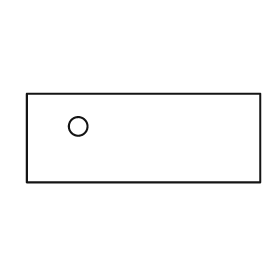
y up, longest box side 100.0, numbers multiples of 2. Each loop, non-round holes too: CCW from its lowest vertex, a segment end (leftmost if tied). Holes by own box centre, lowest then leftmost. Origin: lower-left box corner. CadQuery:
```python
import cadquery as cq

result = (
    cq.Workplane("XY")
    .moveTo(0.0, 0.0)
    .lineTo(100.0, 0.0)
    .lineTo(100.0, 38.0)
    .lineTo(0.0, 38.0)
    .close()
    .moveTo(22.0, 24.0)
    .circle(4.0)
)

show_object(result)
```